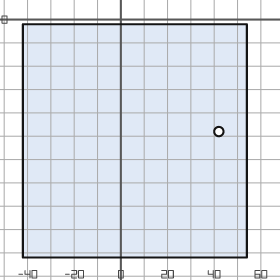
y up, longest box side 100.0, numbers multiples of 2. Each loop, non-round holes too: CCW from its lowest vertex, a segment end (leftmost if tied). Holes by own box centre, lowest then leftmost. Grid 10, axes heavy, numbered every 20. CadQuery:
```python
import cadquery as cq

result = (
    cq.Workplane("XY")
    .moveTo(-42.0, -102.0)
    .lineTo(54.0, -102.0)
    .lineTo(54.0, -2.0)
    .lineTo(-42.0, -2.0)
    .close()
    .moveTo(42.0, -48.0)
    .circle(2.0)
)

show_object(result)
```